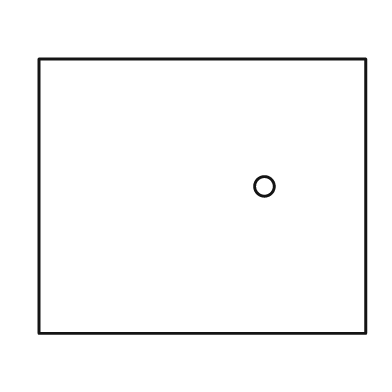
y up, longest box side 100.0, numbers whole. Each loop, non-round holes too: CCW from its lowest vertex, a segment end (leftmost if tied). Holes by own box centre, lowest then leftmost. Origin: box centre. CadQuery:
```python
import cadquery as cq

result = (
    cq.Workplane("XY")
    .moveTo(-50.0, -42.0)
    .lineTo(50.0, -42.0)
    .lineTo(50.0, 42.0)
    .lineTo(-50.0, 42.0)
    .close()
    .moveTo(19.0, 3.0)
    .circle(3.0)
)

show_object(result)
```